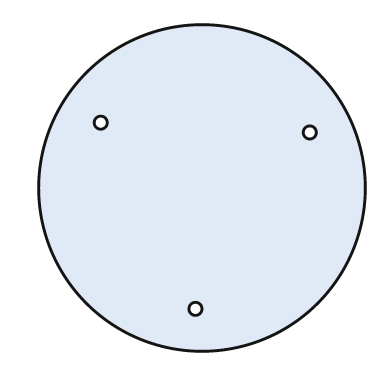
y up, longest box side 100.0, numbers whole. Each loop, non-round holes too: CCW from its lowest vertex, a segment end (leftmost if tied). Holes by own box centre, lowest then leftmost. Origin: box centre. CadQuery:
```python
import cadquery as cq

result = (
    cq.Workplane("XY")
    .moveTo(0.0, 0.0)
    .circle(50.0)
    .moveTo(-2.0, -37.0)
    .circle(2.0)
    .moveTo(33.0, 17.0)
    .circle(2.0)
    .moveTo(-31.0, 20.0)
    .circle(2.0)
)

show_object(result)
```